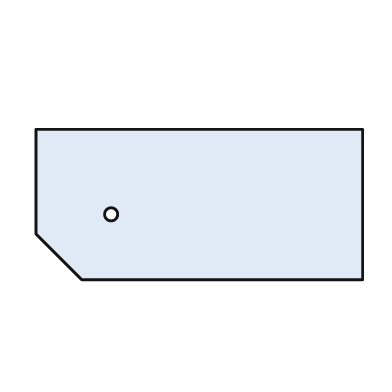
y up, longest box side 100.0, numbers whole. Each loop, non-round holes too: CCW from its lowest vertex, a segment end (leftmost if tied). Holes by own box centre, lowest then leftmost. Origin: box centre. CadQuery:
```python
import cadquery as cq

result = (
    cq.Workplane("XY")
    .moveTo(-36.0, -23.0)
    .lineTo(50.0, -23.0)
    .lineTo(50.0, 23.0)
    .lineTo(-50.0, 23.0)
    .lineTo(-50.0, -9.0)
    .close()
    .moveTo(-27.0, -3.0)
    .circle(2.0)
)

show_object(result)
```